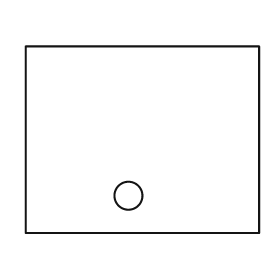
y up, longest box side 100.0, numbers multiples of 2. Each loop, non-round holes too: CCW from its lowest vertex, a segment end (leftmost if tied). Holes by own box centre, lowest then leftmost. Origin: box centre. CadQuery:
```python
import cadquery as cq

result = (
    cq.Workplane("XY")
    .moveTo(-50.0, -40.0)
    .lineTo(50.0, -40.0)
    .lineTo(50.0, 40.0)
    .lineTo(-50.0, 40.0)
    .close()
    .moveTo(-6.0, -24.0)
    .circle(6.0)
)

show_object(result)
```